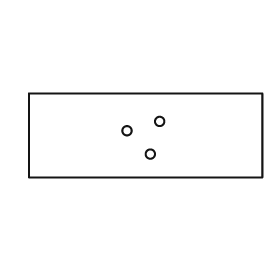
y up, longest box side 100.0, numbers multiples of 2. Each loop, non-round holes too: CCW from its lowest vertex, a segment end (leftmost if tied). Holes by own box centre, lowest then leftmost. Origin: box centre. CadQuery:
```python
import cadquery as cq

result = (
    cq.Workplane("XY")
    .moveTo(-50.0, -18.0)
    .lineTo(50.0, -18.0)
    .lineTo(50.0, 18.0)
    .lineTo(-50.0, 18.0)
    .close()
    .moveTo(2.0, -8.0)
    .circle(2.0)
    .moveTo(-8.0, 2.0)
    .circle(2.0)
    .moveTo(6.0, 6.0)
    .circle(2.0)
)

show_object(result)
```